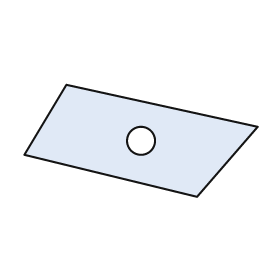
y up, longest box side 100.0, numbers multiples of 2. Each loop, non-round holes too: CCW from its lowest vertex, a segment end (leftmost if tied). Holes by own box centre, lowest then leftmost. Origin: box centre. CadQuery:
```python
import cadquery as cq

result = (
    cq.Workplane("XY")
    .moveTo(24.0, -24.0)
    .lineTo(50.0, 6.0)
    .lineTo(-32.0, 24.0)
    .lineTo(-50.0, -6.0)
    .close()
    .moveTo(0.0, 0.0)
    .circle(6.0)
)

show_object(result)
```